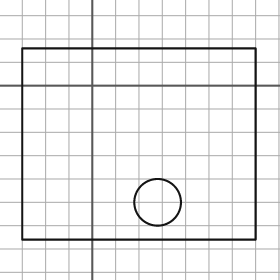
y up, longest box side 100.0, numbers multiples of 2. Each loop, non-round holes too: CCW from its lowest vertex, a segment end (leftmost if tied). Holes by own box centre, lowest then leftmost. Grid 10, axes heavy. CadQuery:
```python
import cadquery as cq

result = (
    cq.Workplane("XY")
    .moveTo(-30.0, -66.0)
    .lineTo(70.0, -66.0)
    .lineTo(70.0, 16.0)
    .lineTo(-30.0, 16.0)
    .close()
    .moveTo(28.0, -50.0)
    .circle(10.0)
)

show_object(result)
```